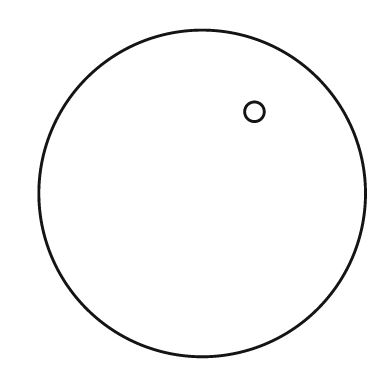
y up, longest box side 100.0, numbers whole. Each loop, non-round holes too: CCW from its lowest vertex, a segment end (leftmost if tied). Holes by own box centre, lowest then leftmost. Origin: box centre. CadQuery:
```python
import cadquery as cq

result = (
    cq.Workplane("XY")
    .moveTo(0.0, 0.0)
    .circle(50.0)
    .moveTo(16.0, 25.0)
    .circle(3.0)
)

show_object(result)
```